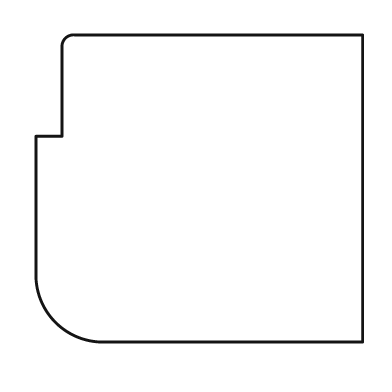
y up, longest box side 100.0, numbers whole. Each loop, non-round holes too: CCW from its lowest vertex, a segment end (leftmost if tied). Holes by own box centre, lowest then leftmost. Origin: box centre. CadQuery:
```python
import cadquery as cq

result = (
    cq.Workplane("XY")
    .moveTo(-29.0, -47.0)
    .lineTo(50.0, -47.0)
    .lineTo(50.0, 47.0)
    .lineTo(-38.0, 47.0)
    .threePointArc((-41.0, 46.0), (-42.0, 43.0))
    .lineTo(-42.0, 16.0)
    .lineTo(-50.0, 16.0)
    .lineTo(-50.0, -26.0)
    .threePointArc((-44.0, -41.0), (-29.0, -47.0))
    .close()
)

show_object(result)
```